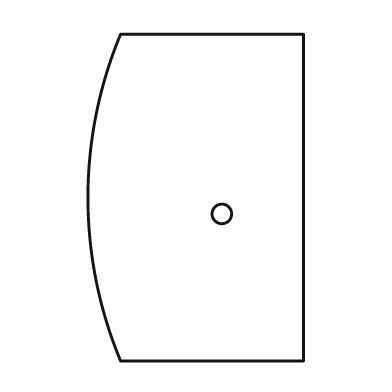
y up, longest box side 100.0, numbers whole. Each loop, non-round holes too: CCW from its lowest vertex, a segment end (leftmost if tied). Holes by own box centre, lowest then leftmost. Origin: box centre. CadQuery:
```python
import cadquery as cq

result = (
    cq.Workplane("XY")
    .moveTo(-23.0, -50.0)
    .lineTo(33.0, -50.0)
    .lineTo(33.0, 50.0)
    .lineTo(-23.0, 50.0)
    .threePointArc((-33.0, 0.0), (-23.0, -50.0))
    .close()
    .moveTo(8.0, -5.0)
    .circle(3.0)
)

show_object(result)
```